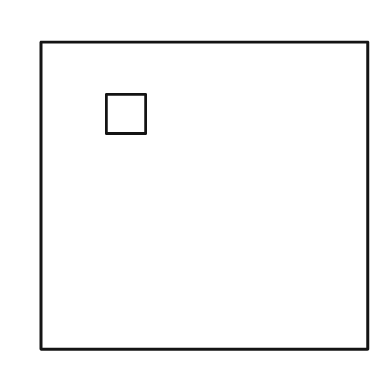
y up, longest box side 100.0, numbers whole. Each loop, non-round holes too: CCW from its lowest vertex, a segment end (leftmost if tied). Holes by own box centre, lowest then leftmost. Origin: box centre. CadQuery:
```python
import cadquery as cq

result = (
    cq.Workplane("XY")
    .moveTo(-50.0, -47.0)
    .lineTo(50.0, -47.0)
    .lineTo(50.0, 47.0)
    .lineTo(-50.0, 47.0)
    .close()
    .moveTo(-30.0, 19.0)
    .lineTo(-18.0, 19.0)
    .lineTo(-18.0, 31.0)
    .lineTo(-30.0, 31.0)
    .close()
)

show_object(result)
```